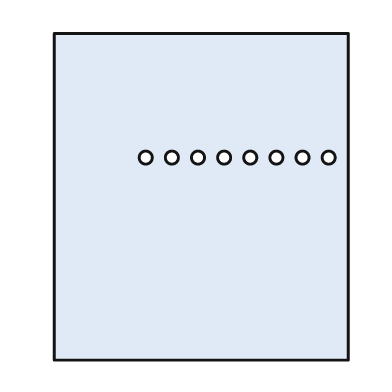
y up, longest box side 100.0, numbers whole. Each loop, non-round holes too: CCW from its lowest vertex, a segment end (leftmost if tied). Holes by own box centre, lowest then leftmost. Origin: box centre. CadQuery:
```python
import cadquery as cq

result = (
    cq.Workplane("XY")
    .moveTo(-45.0, -50.0)
    .lineTo(45.0, -50.0)
    .lineTo(45.0, 50.0)
    .lineTo(-45.0, 50.0)
    .close()
    .moveTo(-17.0, 12.0)
    .circle(2.0)
    .moveTo(-9.0, 12.0)
    .circle(2.0)
    .moveTo(-1.0, 12.0)
    .circle(2.0)
    .moveTo(7.0, 12.0)
    .circle(2.0)
    .moveTo(15.0, 12.0)
    .circle(2.0)
    .moveTo(23.0, 12.0)
    .circle(2.0)
    .moveTo(31.0, 12.0)
    .circle(2.0)
    .moveTo(39.0, 12.0)
    .circle(2.0)
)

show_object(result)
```